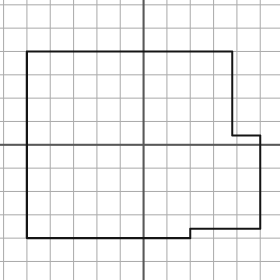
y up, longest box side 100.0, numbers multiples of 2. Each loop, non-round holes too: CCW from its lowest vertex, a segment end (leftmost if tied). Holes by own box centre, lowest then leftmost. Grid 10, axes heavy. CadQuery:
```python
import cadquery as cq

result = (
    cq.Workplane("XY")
    .moveTo(-50.0, -40.0)
    .lineTo(20.0, -40.0)
    .lineTo(20.0, -36.0)
    .lineTo(50.0, -36.0)
    .lineTo(50.0, 4.0)
    .lineTo(38.0, 4.0)
    .lineTo(38.0, 40.0)
    .lineTo(-50.0, 40.0)
    .close()
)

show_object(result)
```